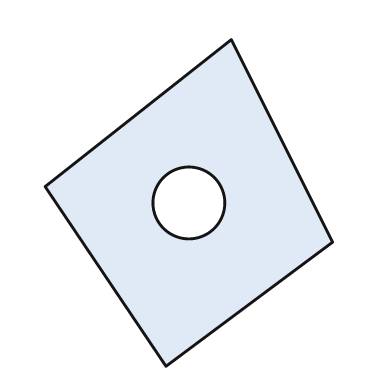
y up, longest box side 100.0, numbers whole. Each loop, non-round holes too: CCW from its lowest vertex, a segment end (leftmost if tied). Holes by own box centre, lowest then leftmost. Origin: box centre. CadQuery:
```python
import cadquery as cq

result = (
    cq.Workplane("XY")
    .moveTo(-7.0, -50.0)
    .lineTo(44.0, -12.0)
    .lineTo(13.0, 50.0)
    .lineTo(-44.0, 5.0)
    .close()
    .moveTo(0.0, 0.0)
    .circle(11.0)
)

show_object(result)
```